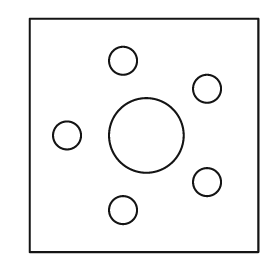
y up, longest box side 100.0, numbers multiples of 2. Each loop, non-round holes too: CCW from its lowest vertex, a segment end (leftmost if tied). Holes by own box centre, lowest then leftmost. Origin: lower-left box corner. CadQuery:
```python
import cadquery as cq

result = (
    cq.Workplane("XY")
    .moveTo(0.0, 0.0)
    .lineTo(98.0, 0.0)
    .lineTo(98.0, 100.0)
    .lineTo(0.0, 100.0)
    .close()
    .moveTo(40.0, 18.0)
    .circle(6.0)
    .moveTo(76.0, 30.0)
    .circle(6.0)
    .moveTo(16.0, 50.0)
    .circle(6.0)
    .moveTo(50.0, 50.0)
    .circle(16.0)
    .moveTo(76.0, 70.0)
    .circle(6.0)
    .moveTo(40.0, 82.0)
    .circle(6.0)
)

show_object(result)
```